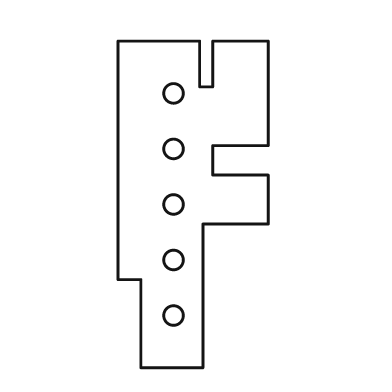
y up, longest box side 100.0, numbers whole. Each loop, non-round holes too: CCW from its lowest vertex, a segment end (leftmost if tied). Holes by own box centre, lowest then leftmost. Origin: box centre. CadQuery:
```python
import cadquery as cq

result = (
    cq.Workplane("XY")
    .moveTo(-16.0, -50.0)
    .lineTo(3.0, -50.0)
    .lineTo(3.0, -6.0)
    .lineTo(23.0, -6.0)
    .lineTo(23.0, 9.0)
    .lineTo(6.0, 9.0)
    .lineTo(6.0, 18.0)
    .lineTo(23.0, 18.0)
    .lineTo(23.0, 50.0)
    .lineTo(6.0, 50.0)
    .lineTo(6.0, 36.0)
    .lineTo(2.0, 36.0)
    .lineTo(2.0, 50.0)
    .lineTo(-23.0, 50.0)
    .lineTo(-23.0, -23.0)
    .lineTo(-16.0, -23.0)
    .close()
    .moveTo(-6.0, -34.0)
    .circle(3.0)
    .moveTo(-6.0, -17.0)
    .circle(3.0)
    .moveTo(-6.0, 0.0)
    .circle(3.0)
    .moveTo(-6.0, 17.0)
    .circle(3.0)
    .moveTo(-6.0, 34.0)
    .circle(3.0)
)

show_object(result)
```